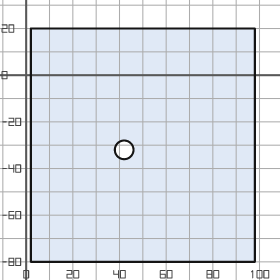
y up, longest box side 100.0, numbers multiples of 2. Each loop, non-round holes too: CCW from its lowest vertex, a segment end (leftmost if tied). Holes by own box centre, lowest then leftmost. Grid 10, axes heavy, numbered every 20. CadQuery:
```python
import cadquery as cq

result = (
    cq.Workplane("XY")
    .moveTo(2.0, -80.0)
    .lineTo(98.0, -80.0)
    .lineTo(98.0, 20.0)
    .lineTo(2.0, 20.0)
    .close()
    .moveTo(42.0, -32.0)
    .circle(4.0)
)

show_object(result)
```